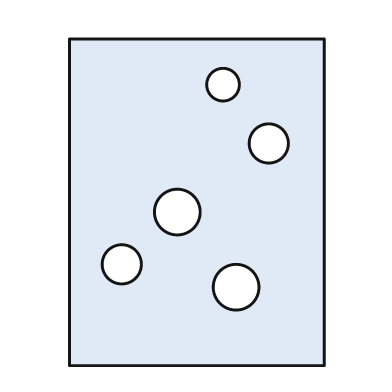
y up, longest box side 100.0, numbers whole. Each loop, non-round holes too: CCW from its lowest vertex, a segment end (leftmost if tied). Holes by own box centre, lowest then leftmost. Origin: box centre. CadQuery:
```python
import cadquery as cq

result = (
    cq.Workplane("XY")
    .moveTo(-39.0, -50.0)
    .lineTo(39.0, -50.0)
    .lineTo(39.0, 50.0)
    .lineTo(-39.0, 50.0)
    .close()
    .moveTo(12.0, -26.0)
    .circle(7.0)
    .moveTo(-23.0, -19.0)
    .circle(6.0)
    .moveTo(-6.0, -3.0)
    .circle(7.0)
    .moveTo(22.0, 18.0)
    .circle(6.0)
    .moveTo(8.0, 36.0)
    .circle(5.0)
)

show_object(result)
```